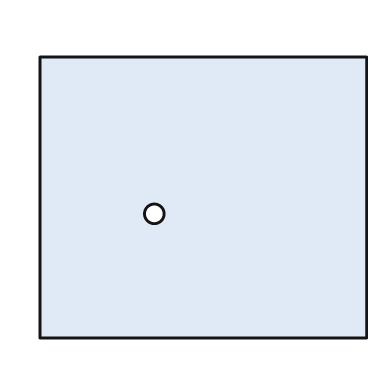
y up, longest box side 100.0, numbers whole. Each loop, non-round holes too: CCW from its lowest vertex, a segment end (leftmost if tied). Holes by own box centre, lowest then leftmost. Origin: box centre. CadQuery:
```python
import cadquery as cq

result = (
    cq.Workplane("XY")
    .moveTo(-50.0, -43.0)
    .lineTo(50.0, -43.0)
    .lineTo(50.0, 43.0)
    .lineTo(-50.0, 43.0)
    .close()
    .moveTo(-15.0, -5.0)
    .circle(3.0)
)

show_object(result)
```